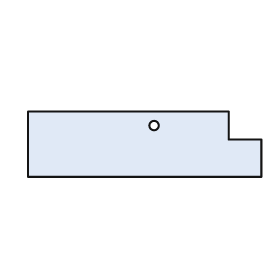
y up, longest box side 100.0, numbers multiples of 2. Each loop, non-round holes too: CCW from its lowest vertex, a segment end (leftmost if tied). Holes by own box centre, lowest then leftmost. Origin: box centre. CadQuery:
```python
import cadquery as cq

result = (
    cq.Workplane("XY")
    .moveTo(-50.0, -14.0)
    .lineTo(50.0, -14.0)
    .lineTo(50.0, 2.0)
    .lineTo(36.0, 2.0)
    .lineTo(36.0, 14.0)
    .lineTo(-50.0, 14.0)
    .close()
    .moveTo(4.0, 8.0)
    .circle(2.0)
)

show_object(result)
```